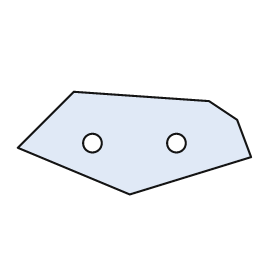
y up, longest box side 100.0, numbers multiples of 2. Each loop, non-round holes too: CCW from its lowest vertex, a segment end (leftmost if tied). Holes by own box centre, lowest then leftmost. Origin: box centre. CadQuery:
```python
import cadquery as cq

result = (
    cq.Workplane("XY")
    .moveTo(-2.0, -22.0)
    .lineTo(50.0, -6.0)
    .lineTo(44.0, 10.0)
    .lineTo(32.0, 18.0)
    .lineTo(-26.0, 22.0)
    .lineTo(-50.0, -2.0)
    .close()
    .moveTo(-18.0, 0.0)
    .circle(4.0)
    .moveTo(18.0, 0.0)
    .circle(4.0)
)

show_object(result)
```